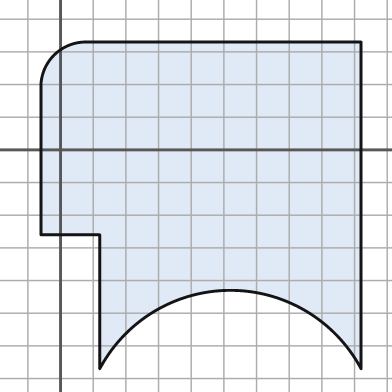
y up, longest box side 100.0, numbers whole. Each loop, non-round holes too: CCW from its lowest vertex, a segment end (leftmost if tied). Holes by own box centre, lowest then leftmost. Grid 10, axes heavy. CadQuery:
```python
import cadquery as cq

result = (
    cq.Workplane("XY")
    .moveTo(12.0, -67.0)
    .threePointArc((52.0, -43.0), (92.0, -67.0))
    .lineTo(92.0, 33.0)
    .lineTo(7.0, 33.0)
    .threePointArc((-2.0, 29.0), (-6.0, 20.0))
    .lineTo(-6.0, -26.0)
    .lineTo(12.0, -26.0)
    .close()
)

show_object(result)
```